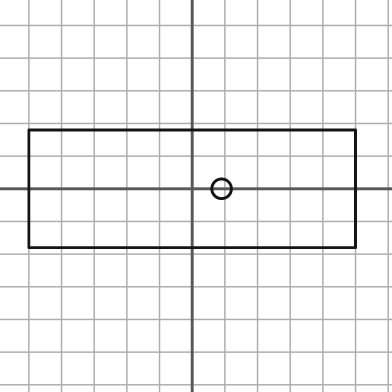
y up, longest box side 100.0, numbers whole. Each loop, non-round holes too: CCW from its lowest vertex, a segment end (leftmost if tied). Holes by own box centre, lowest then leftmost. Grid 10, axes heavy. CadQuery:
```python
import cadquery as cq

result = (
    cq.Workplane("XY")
    .moveTo(-50.0, -18.0)
    .lineTo(50.0, -18.0)
    .lineTo(50.0, 18.0)
    .lineTo(-50.0, 18.0)
    .close()
    .moveTo(9.0, 0.0)
    .circle(3.0)
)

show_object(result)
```